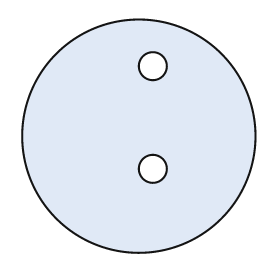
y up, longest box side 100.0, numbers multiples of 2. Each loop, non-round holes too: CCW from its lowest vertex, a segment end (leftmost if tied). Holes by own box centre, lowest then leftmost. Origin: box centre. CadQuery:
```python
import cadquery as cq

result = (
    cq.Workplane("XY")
    .moveTo(0.0, 0.0)
    .circle(50.0)
    .moveTo(6.0, -14.0)
    .circle(6.0)
    .moveTo(6.0, 30.0)
    .circle(6.0)
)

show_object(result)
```